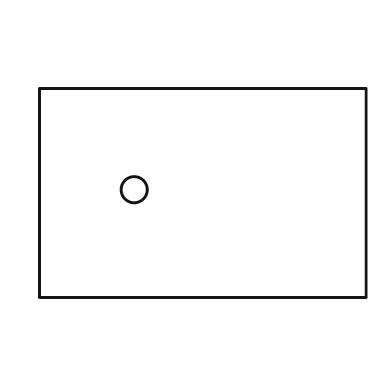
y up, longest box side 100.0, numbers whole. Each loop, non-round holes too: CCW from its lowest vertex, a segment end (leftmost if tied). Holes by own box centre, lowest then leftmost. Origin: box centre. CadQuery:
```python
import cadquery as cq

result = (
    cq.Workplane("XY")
    .moveTo(-50.0, -32.0)
    .lineTo(50.0, -32.0)
    .lineTo(50.0, 32.0)
    .lineTo(-50.0, 32.0)
    .close()
    .moveTo(-21.0, 1.0)
    .circle(4.0)
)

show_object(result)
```